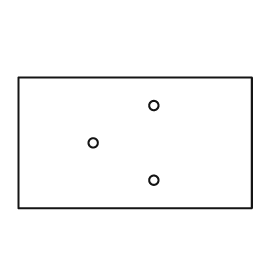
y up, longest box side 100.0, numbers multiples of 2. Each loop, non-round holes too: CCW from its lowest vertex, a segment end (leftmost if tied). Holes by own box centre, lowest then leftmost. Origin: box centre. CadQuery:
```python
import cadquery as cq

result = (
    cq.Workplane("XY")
    .moveTo(-50.0, -28.0)
    .lineTo(50.0, -28.0)
    .lineTo(50.0, 28.0)
    .lineTo(-50.0, 28.0)
    .close()
    .moveTo(8.0, -16.0)
    .circle(2.0)
    .moveTo(-18.0, 0.0)
    .circle(2.0)
    .moveTo(8.0, 16.0)
    .circle(2.0)
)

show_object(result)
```